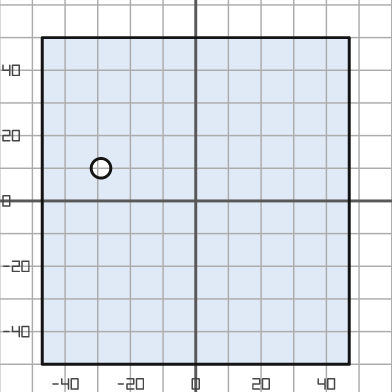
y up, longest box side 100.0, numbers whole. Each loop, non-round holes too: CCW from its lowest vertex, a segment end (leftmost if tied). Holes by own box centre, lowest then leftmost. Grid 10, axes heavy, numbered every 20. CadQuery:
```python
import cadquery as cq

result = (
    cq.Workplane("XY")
    .moveTo(-47.0, -50.0)
    .lineTo(47.0, -50.0)
    .lineTo(47.0, 50.0)
    .lineTo(-47.0, 50.0)
    .close()
    .moveTo(-29.0, 10.0)
    .circle(3.0)
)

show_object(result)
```